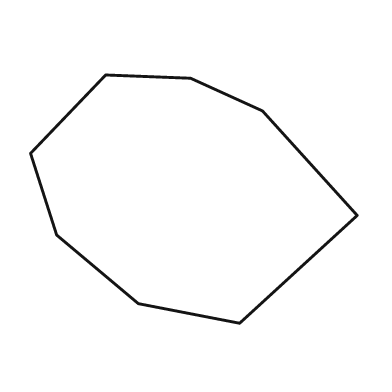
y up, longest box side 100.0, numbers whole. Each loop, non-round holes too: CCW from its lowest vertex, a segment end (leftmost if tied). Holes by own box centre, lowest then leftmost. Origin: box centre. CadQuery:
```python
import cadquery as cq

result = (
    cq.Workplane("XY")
    .moveTo(14.0, -38.0)
    .lineTo(50.0, -5.0)
    .lineTo(21.0, 27.0)
    .lineTo(-1.0, 37.0)
    .lineTo(-27.0, 38.0)
    .lineTo(-50.0, 14.0)
    .lineTo(-42.0, -11.0)
    .lineTo(-17.0, -32.0)
    .close()
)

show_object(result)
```